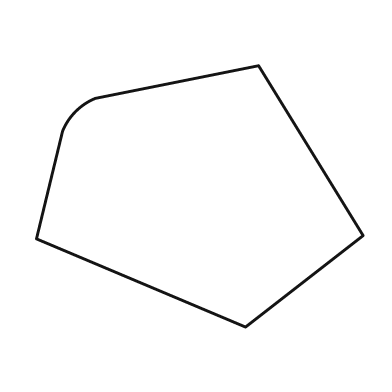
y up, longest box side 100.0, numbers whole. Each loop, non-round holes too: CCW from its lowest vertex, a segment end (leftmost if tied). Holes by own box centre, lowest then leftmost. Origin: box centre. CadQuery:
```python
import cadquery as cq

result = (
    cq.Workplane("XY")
    .moveTo(14.0, -40.0)
    .lineTo(50.0, -12.0)
    .lineTo(18.0, 40.0)
    .lineTo(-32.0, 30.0)
    .threePointArc((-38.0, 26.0), (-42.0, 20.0))
    .lineTo(-50.0, -13.0)
    .close()
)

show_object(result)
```